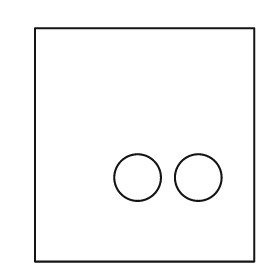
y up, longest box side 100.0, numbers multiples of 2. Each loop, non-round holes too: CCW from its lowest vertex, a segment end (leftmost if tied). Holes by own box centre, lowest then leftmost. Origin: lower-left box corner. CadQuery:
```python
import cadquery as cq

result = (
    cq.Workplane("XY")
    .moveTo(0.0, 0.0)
    .lineTo(94.0, 0.0)
    .lineTo(94.0, 100.0)
    .lineTo(0.0, 100.0)
    .close()
    .moveTo(44.0, 36.0)
    .circle(10.0)
    .moveTo(70.0, 36.0)
    .circle(10.0)
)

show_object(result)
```